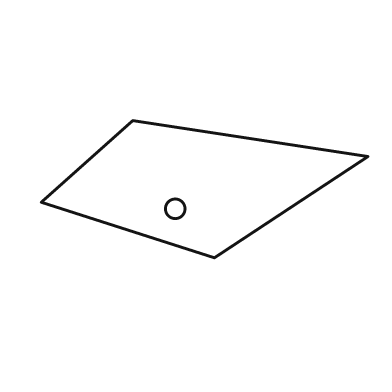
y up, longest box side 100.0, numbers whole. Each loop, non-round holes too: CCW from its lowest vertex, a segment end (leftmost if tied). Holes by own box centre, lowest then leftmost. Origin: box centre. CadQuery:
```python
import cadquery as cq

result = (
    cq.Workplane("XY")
    .moveTo(3.0, -21.0)
    .lineTo(50.0, 10.0)
    .lineTo(-22.0, 21.0)
    .lineTo(-50.0, -4.0)
    .close()
    .moveTo(-9.0, -6.0)
    .circle(3.0)
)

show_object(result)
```